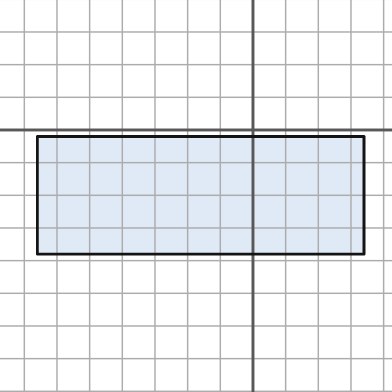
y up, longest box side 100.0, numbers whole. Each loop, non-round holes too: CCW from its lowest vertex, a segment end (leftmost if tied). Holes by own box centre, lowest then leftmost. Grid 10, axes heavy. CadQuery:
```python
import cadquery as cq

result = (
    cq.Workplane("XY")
    .moveTo(-66.0, -38.0)
    .lineTo(34.0, -38.0)
    .lineTo(34.0, -2.0)
    .lineTo(-66.0, -2.0)
    .close()
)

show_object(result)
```